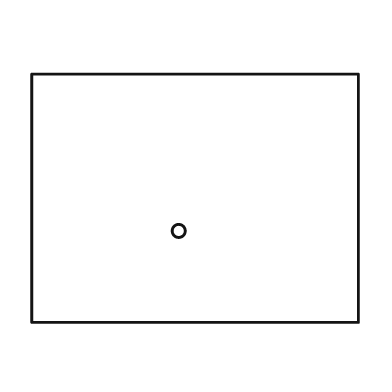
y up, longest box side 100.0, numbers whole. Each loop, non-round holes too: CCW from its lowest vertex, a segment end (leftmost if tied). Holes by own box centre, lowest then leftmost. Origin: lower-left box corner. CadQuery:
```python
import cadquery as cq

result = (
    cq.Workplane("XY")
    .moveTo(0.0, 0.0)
    .lineTo(100.0, 0.0)
    .lineTo(100.0, 76.0)
    .lineTo(0.0, 76.0)
    .close()
    .moveTo(45.0, 28.0)
    .circle(2.0)
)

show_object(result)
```